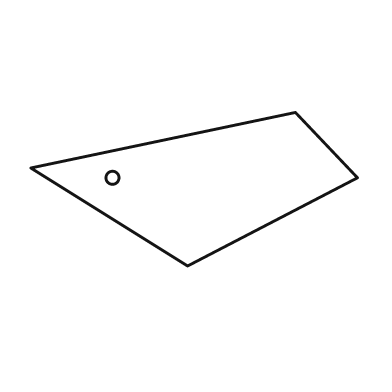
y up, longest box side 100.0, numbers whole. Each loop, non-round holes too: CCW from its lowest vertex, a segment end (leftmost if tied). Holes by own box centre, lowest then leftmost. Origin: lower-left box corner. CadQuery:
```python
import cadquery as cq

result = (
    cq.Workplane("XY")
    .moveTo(48.0, 0.0)
    .lineTo(100.0, 27.0)
    .lineTo(81.0, 47.0)
    .lineTo(0.0, 30.0)
    .close()
    .moveTo(25.0, 27.0)
    .circle(2.0)
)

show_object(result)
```